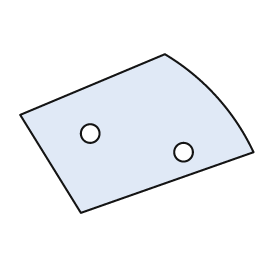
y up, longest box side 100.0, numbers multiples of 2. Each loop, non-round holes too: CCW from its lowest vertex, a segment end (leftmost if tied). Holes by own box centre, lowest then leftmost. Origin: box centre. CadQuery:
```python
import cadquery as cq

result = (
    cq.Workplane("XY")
    .moveTo(-24.0, -34.0)
    .lineTo(50.0, -8.0)
    .threePointArc((34.0, 16.0), (12.0, 34.0))
    .lineTo(-50.0, 8.0)
    .close()
    .moveTo(20.0, -8.0)
    .circle(4.0)
    .moveTo(-20.0, 0.0)
    .circle(4.0)
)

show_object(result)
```